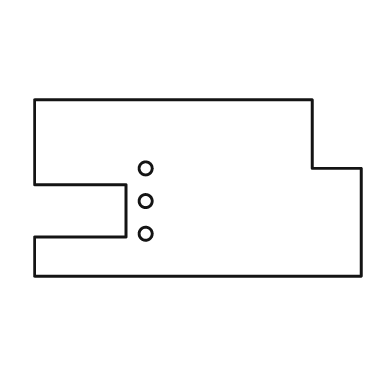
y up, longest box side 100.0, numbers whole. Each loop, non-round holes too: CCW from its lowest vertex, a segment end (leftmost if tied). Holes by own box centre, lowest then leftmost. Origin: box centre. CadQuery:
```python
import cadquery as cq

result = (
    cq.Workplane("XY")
    .moveTo(-50.0, -27.0)
    .lineTo(50.0, -27.0)
    .lineTo(50.0, 6.0)
    .lineTo(35.0, 6.0)
    .lineTo(35.0, 27.0)
    .lineTo(-50.0, 27.0)
    .lineTo(-50.0, 1.0)
    .lineTo(-22.0, 1.0)
    .lineTo(-22.0, -15.0)
    .lineTo(-50.0, -15.0)
    .close()
    .moveTo(-16.0, -14.0)
    .circle(2.0)
    .moveTo(-16.0, -4.0)
    .circle(2.0)
    .moveTo(-16.0, 6.0)
    .circle(2.0)
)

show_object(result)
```